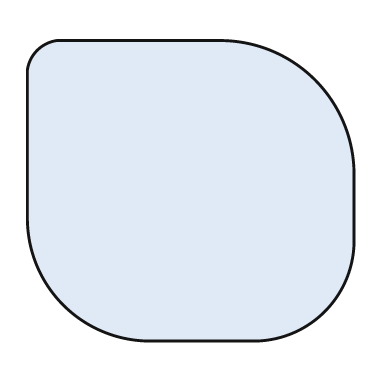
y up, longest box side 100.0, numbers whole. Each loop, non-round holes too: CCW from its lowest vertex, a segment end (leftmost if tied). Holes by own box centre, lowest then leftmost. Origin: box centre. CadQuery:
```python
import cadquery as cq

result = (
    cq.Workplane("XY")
    .moveTo(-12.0, -46.0)
    .lineTo(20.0, -46.0)
    .threePointArc((41.0, -37.0), (50.0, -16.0))
    .lineTo(50.0, 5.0)
    .threePointArc((38.0, 34.0), (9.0, 46.0))
    .lineTo(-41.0, 46.0)
    .threePointArc((-47.0, 43.0), (-50.0, 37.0))
    .lineTo(-50.0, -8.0)
    .threePointArc((-39.0, -35.0), (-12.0, -46.0))
    .close()
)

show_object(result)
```